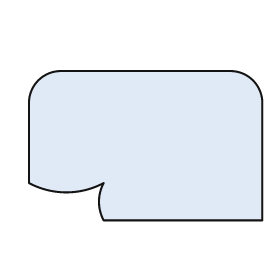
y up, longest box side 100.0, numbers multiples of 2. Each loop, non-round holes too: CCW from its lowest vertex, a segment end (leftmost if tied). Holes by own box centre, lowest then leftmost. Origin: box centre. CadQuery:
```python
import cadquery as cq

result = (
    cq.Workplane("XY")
    .moveTo(-18.0, -32.0)
    .lineTo(50.0, -32.0)
    .lineTo(50.0, 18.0)
    .threePointArc((46.0, 28.0), (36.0, 32.0))
    .lineTo(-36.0, 32.0)
    .threePointArc((-46.0, 28.0), (-50.0, 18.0))
    .lineTo(-50.0, -16.0)
    .threePointArc((-34.0, -20.0), (-18.0, -16.0))
    .threePointArc((-20.0, -24.0), (-18.0, -32.0))
    .close()
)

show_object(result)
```